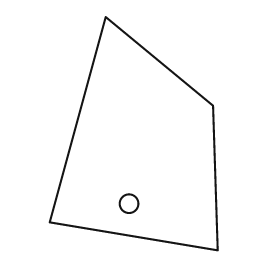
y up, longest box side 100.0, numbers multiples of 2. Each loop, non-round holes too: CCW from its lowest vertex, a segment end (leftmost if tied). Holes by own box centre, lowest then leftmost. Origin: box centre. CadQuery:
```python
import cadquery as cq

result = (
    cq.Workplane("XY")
    .moveTo(36.0, -50.0)
    .lineTo(34.0, 12.0)
    .lineTo(-12.0, 50.0)
    .lineTo(-36.0, -38.0)
    .close()
    .moveTo(-2.0, -30.0)
    .circle(4.0)
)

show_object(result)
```